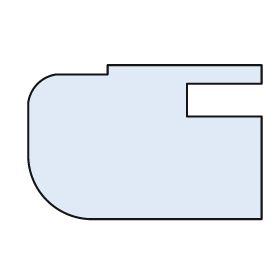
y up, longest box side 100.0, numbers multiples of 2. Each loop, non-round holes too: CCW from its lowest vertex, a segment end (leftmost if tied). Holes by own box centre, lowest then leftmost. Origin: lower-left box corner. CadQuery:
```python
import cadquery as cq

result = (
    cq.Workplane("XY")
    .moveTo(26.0, 0.0)
    .lineTo(100.0, 0.0)
    .lineTo(100.0, 44.0)
    .lineTo(68.0, 44.0)
    .lineTo(68.0, 58.0)
    .lineTo(100.0, 58.0)
    .lineTo(100.0, 66.0)
    .lineTo(34.0, 66.0)
    .lineTo(34.0, 62.0)
    .lineTo(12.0, 62.0)
    .threePointArc((4.0, 58.0), (0.0, 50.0))
    .lineTo(0.0, 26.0)
    .threePointArc((8.0, 8.0), (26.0, 0.0))
    .close()
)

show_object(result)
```